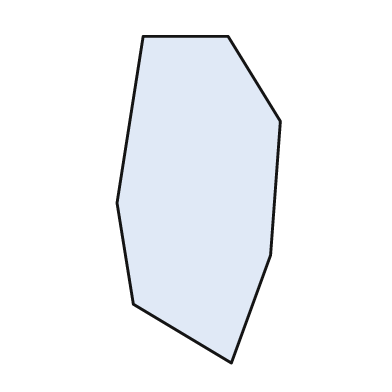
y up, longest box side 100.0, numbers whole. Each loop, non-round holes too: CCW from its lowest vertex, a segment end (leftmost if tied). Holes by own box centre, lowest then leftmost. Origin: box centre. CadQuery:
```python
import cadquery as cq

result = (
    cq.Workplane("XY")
    .moveTo(10.0, -50.0)
    .lineTo(22.0, -17.0)
    .lineTo(25.0, 24.0)
    .lineTo(9.0, 50.0)
    .lineTo(-17.0, 50.0)
    .lineTo(-25.0, -1.0)
    .lineTo(-20.0, -32.0)
    .close()
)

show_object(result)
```